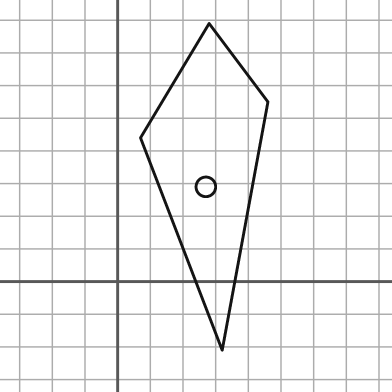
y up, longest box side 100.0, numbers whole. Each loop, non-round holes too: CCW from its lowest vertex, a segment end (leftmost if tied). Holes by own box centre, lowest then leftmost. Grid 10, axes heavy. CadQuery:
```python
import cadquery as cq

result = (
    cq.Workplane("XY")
    .moveTo(32.0, -21.0)
    .lineTo(46.0, 55.0)
    .lineTo(28.0, 79.0)
    .lineTo(7.0, 44.0)
    .close()
    .moveTo(27.0, 29.0)
    .circle(3.0)
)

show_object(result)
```